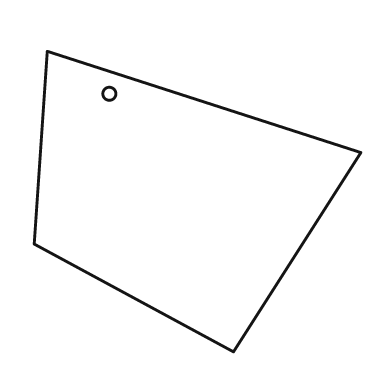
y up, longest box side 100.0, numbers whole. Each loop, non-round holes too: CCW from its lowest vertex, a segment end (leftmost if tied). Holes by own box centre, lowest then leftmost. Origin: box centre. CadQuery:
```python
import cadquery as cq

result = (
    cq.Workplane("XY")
    .moveTo(11.0, -46.0)
    .lineTo(50.0, 15.0)
    .lineTo(-46.0, 46.0)
    .lineTo(-50.0, -13.0)
    .close()
    .moveTo(-27.0, 33.0)
    .circle(2.0)
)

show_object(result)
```